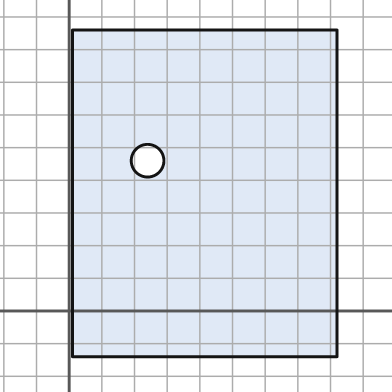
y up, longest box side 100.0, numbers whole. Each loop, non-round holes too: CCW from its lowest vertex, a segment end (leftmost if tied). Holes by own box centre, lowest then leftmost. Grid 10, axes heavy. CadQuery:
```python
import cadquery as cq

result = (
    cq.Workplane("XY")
    .moveTo(1.0, -14.0)
    .lineTo(82.0, -14.0)
    .lineTo(82.0, 86.0)
    .lineTo(1.0, 86.0)
    .close()
    .moveTo(24.0, 46.0)
    .circle(5.0)
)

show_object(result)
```